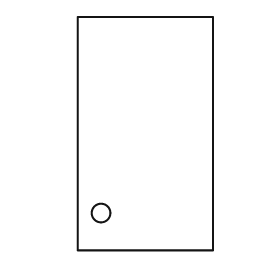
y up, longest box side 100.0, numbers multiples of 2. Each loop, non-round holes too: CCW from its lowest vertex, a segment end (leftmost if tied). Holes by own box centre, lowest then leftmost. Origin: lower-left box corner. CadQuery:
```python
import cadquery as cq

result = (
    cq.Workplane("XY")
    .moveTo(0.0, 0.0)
    .lineTo(58.0, 0.0)
    .lineTo(58.0, 100.0)
    .lineTo(0.0, 100.0)
    .close()
    .moveTo(10.0, 16.0)
    .circle(4.0)
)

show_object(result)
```